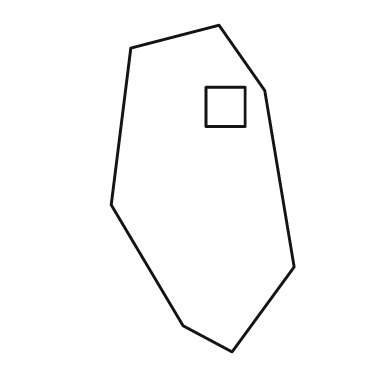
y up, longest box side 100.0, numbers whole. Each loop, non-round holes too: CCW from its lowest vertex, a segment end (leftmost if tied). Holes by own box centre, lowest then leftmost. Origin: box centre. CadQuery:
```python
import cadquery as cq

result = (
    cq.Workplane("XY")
    .moveTo(9.0, -50.0)
    .lineTo(28.0, -24.0)
    .lineTo(19.0, 30.0)
    .lineTo(5.0, 50.0)
    .lineTo(-22.0, 43.0)
    .lineTo(-28.0, -5.0)
    .lineTo(-6.0, -42.0)
    .close()
    .moveTo(1.0, 19.0)
    .lineTo(13.0, 19.0)
    .lineTo(13.0, 31.0)
    .lineTo(1.0, 31.0)
    .close()
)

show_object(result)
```